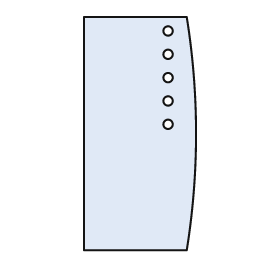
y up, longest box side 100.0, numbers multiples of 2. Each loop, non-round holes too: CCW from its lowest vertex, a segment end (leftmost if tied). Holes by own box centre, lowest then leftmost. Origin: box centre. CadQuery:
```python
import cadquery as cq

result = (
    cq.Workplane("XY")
    .moveTo(-24.0, -50.0)
    .lineTo(20.0, -50.0)
    .threePointArc((24.0, 0.0), (20.0, 50.0))
    .lineTo(-24.0, 50.0)
    .close()
    .moveTo(12.0, 4.0)
    .circle(2.0)
    .moveTo(12.0, 14.0)
    .circle(2.0)
    .moveTo(12.0, 24.0)
    .circle(2.0)
    .moveTo(12.0, 34.0)
    .circle(2.0)
    .moveTo(12.0, 44.0)
    .circle(2.0)
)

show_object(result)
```